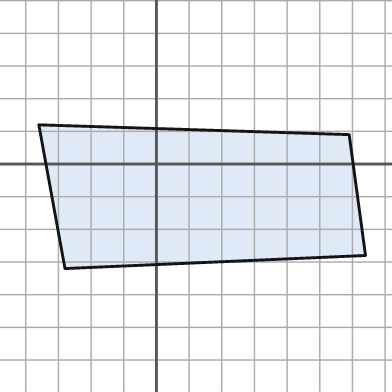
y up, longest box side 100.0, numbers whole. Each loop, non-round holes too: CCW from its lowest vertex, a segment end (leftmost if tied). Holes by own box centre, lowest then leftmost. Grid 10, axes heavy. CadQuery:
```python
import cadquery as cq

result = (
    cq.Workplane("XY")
    .moveTo(-28.0, -32.0)
    .lineTo(64.0, -28.0)
    .lineTo(59.0, 9.0)
    .lineTo(-36.0, 12.0)
    .close()
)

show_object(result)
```